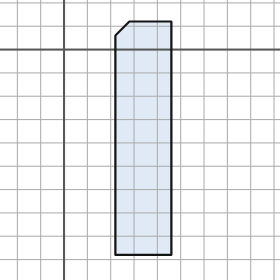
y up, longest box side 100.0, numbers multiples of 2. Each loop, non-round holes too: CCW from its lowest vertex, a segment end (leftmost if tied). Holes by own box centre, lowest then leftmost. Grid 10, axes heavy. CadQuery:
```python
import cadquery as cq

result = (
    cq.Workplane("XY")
    .moveTo(22.0, -88.0)
    .lineTo(46.0, -88.0)
    .lineTo(46.0, 12.0)
    .lineTo(28.0, 12.0)
    .lineTo(22.0, 6.0)
    .close()
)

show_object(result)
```